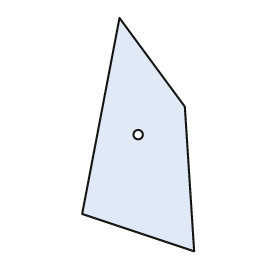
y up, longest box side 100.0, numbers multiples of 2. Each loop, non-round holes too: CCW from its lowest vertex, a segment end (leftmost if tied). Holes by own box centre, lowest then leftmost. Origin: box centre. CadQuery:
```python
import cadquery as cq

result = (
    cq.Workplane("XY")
    .moveTo(24.0, -50.0)
    .lineTo(20.0, 12.0)
    .lineTo(-8.0, 50.0)
    .lineTo(-24.0, -34.0)
    .close()
    .moveTo(0.0, 0.0)
    .circle(2.0)
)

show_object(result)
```